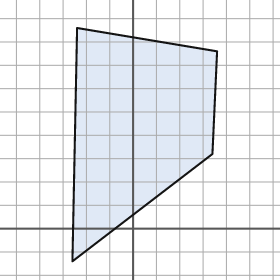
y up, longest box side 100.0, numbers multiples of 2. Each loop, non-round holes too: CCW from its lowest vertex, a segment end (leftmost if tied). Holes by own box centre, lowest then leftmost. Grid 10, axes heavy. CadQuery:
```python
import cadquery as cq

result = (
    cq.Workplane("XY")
    .moveTo(-26.0, -14.0)
    .lineTo(34.0, 32.0)
    .lineTo(36.0, 76.0)
    .lineTo(-24.0, 86.0)
    .close()
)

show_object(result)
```